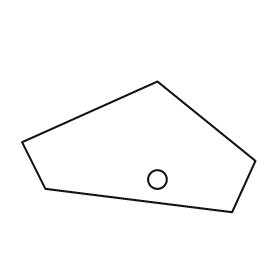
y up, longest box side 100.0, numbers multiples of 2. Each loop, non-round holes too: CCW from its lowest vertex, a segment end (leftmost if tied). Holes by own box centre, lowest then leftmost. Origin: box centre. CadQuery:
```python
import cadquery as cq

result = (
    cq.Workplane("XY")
    .moveTo(40.0, -28.0)
    .lineTo(50.0, -6.0)
    .lineTo(8.0, 28.0)
    .lineTo(-50.0, 2.0)
    .lineTo(-40.0, -18.0)
    .close()
    .moveTo(8.0, -14.0)
    .circle(4.0)
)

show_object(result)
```